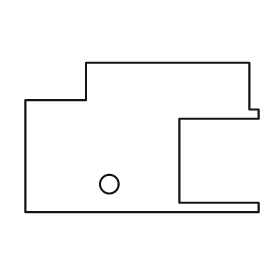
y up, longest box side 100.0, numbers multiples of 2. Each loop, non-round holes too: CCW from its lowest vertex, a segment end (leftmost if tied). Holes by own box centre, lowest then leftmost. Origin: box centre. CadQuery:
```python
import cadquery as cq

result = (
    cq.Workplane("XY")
    .moveTo(-50.0, -32.0)
    .lineTo(50.0, -32.0)
    .lineTo(50.0, -28.0)
    .lineTo(16.0, -28.0)
    .lineTo(16.0, 8.0)
    .lineTo(50.0, 8.0)
    .lineTo(50.0, 12.0)
    .lineTo(46.0, 12.0)
    .lineTo(46.0, 32.0)
    .lineTo(-24.0, 32.0)
    .lineTo(-24.0, 16.0)
    .lineTo(-50.0, 16.0)
    .close()
    .moveTo(-14.0, -20.0)
    .circle(4.0)
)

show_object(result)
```